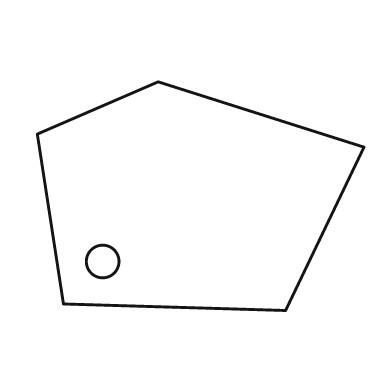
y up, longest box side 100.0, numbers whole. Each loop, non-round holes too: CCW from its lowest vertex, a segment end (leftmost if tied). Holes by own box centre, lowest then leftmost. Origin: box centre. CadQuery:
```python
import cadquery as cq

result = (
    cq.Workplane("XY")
    .moveTo(26.0, -35.0)
    .lineTo(50.0, 15.0)
    .lineTo(-13.0, 35.0)
    .lineTo(-50.0, 19.0)
    .lineTo(-42.0, -33.0)
    .close()
    .moveTo(-30.0, -20.0)
    .circle(5.0)
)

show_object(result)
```